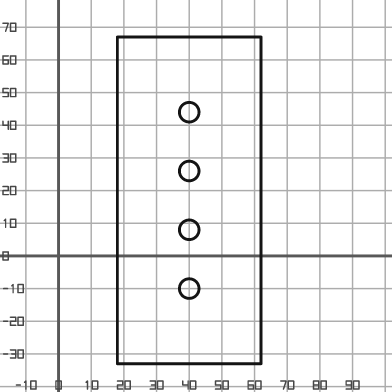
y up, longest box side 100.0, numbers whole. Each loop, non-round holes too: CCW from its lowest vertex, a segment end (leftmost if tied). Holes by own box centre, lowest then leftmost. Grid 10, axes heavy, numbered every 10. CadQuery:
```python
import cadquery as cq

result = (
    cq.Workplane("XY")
    .moveTo(18.0, -33.0)
    .lineTo(62.0, -33.0)
    .lineTo(62.0, 67.0)
    .lineTo(18.0, 67.0)
    .close()
    .moveTo(40.0, -10.0)
    .circle(3.0)
    .moveTo(40.0, 8.0)
    .circle(3.0)
    .moveTo(40.0, 26.0)
    .circle(3.0)
    .moveTo(40.0, 44.0)
    .circle(3.0)
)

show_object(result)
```